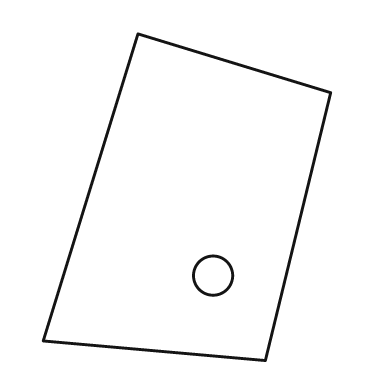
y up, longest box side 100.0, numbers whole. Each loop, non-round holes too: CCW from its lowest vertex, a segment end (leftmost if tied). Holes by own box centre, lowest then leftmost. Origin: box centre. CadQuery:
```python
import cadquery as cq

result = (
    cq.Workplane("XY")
    .moveTo(24.0, -50.0)
    .lineTo(44.0, 32.0)
    .lineTo(-15.0, 50.0)
    .lineTo(-44.0, -44.0)
    .close()
    .moveTo(8.0, -24.0)
    .circle(6.0)
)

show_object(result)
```